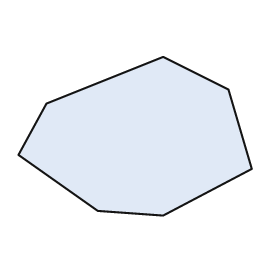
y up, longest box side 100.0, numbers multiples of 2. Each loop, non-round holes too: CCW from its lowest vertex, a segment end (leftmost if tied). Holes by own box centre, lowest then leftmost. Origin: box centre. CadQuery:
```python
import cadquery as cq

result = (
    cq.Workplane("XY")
    .moveTo(12.0, -34.0)
    .lineTo(50.0, -14.0)
    .lineTo(40.0, 20.0)
    .lineTo(12.0, 34.0)
    .lineTo(-38.0, 14.0)
    .lineTo(-50.0, -8.0)
    .lineTo(-16.0, -32.0)
    .close()
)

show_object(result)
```